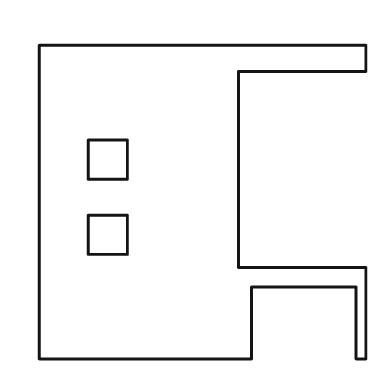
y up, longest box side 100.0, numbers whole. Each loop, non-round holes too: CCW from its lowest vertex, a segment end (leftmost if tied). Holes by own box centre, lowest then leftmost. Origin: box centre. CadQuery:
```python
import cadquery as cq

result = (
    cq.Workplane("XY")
    .moveTo(-50.0, -48.0)
    .lineTo(15.0, -48.0)
    .lineTo(15.0, -26.0)
    .lineTo(47.0, -26.0)
    .lineTo(47.0, -48.0)
    .lineTo(50.0, -48.0)
    .lineTo(50.0, -20.0)
    .lineTo(11.0, -20.0)
    .lineTo(11.0, 40.0)
    .lineTo(50.0, 40.0)
    .lineTo(50.0, 48.0)
    .lineTo(-50.0, 48.0)
    .close()
    .moveTo(-35.0, -16.0)
    .lineTo(-23.0, -16.0)
    .lineTo(-23.0, -4.0)
    .lineTo(-35.0, -4.0)
    .close()
    .moveTo(-35.0, 7.0)
    .lineTo(-23.0, 7.0)
    .lineTo(-23.0, 19.0)
    .lineTo(-35.0, 19.0)
    .close()
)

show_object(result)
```